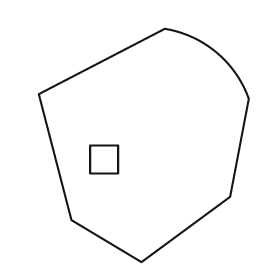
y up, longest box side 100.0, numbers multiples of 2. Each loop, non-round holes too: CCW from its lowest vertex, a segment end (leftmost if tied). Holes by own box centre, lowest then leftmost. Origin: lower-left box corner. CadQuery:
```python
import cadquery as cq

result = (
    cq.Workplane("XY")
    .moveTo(44.0, 0.0)
    .lineTo(82.0, 28.0)
    .lineTo(90.0, 70.0)
    .threePointArc((76.0, 90.0), (54.0, 100.0))
    .lineTo(0.0, 72.0)
    .lineTo(14.0, 18.0)
    .close()
    .moveTo(22.0, 38.0)
    .lineTo(34.0, 38.0)
    .lineTo(34.0, 50.0)
    .lineTo(22.0, 50.0)
    .close()
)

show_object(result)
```